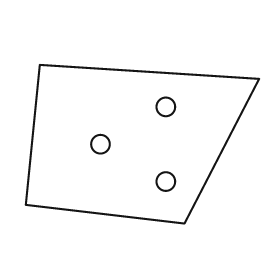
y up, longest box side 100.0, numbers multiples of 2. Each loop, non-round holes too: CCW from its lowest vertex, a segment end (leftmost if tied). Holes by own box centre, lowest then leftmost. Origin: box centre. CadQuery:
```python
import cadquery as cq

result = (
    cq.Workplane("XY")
    .moveTo(18.0, -34.0)
    .lineTo(50.0, 28.0)
    .lineTo(-44.0, 34.0)
    .lineTo(-50.0, -26.0)
    .close()
    .moveTo(10.0, -16.0)
    .circle(4.0)
    .moveTo(-18.0, 0.0)
    .circle(4.0)
    .moveTo(10.0, 16.0)
    .circle(4.0)
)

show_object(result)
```